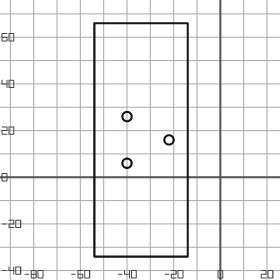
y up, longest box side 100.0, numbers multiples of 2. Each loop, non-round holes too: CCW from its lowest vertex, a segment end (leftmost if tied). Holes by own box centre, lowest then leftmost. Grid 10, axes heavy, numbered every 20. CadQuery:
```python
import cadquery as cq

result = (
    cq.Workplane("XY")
    .moveTo(-54.0, -34.0)
    .lineTo(-14.0, -34.0)
    .lineTo(-14.0, 66.0)
    .lineTo(-54.0, 66.0)
    .close()
    .moveTo(-40.0, 6.0)
    .circle(2.0)
    .moveTo(-22.0, 16.0)
    .circle(2.0)
    .moveTo(-40.0, 26.0)
    .circle(2.0)
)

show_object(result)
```